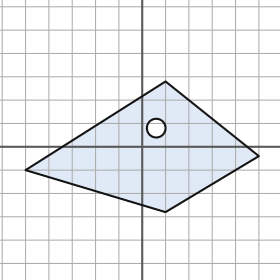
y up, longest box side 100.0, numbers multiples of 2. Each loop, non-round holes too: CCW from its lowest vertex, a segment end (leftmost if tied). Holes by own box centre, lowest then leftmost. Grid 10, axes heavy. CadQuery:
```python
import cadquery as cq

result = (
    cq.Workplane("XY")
    .moveTo(10.0, -28.0)
    .lineTo(50.0, -4.0)
    .lineTo(10.0, 28.0)
    .lineTo(-50.0, -10.0)
    .close()
    .moveTo(6.0, 8.0)
    .circle(4.0)
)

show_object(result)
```